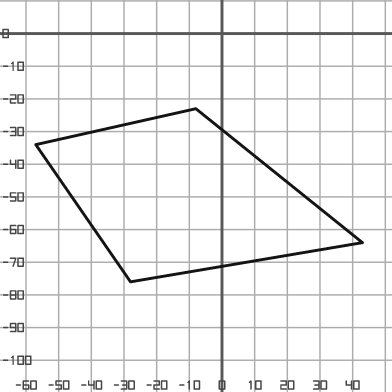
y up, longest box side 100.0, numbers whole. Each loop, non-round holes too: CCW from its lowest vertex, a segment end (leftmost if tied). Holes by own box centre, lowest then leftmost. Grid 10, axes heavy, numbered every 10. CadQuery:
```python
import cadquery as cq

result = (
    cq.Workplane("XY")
    .moveTo(-28.0, -76.0)
    .lineTo(43.0, -64.0)
    .lineTo(-8.0, -23.0)
    .lineTo(-57.0, -34.0)
    .close()
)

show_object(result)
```